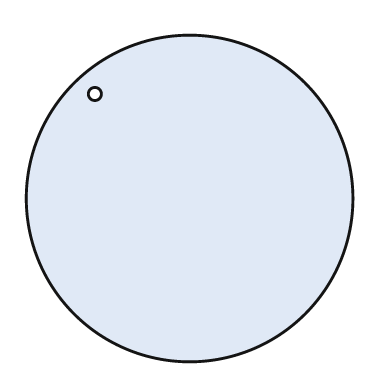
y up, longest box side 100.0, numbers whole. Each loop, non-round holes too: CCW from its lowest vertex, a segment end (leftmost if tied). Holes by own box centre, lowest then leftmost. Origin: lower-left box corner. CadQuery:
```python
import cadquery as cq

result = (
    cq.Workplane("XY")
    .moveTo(50.0, 50.0)
    .circle(50.0)
    .moveTo(21.0, 82.0)
    .circle(2.0)
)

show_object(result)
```